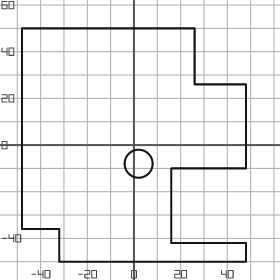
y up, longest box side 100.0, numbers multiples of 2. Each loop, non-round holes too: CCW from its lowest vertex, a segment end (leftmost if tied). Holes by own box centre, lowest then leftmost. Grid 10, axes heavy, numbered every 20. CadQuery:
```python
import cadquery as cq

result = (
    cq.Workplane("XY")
    .moveTo(-32.0, -50.0)
    .lineTo(48.0, -50.0)
    .lineTo(48.0, -42.0)
    .lineTo(16.0, -42.0)
    .lineTo(16.0, -10.0)
    .lineTo(48.0, -10.0)
    .lineTo(48.0, 26.0)
    .lineTo(26.0, 26.0)
    .lineTo(26.0, 50.0)
    .lineTo(-48.0, 50.0)
    .lineTo(-48.0, -36.0)
    .lineTo(-32.0, -36.0)
    .close()
    .moveTo(2.0, -8.0)
    .circle(6.0)
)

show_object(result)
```